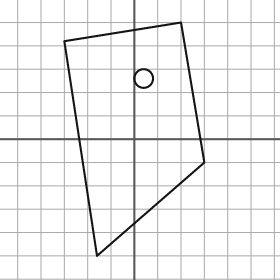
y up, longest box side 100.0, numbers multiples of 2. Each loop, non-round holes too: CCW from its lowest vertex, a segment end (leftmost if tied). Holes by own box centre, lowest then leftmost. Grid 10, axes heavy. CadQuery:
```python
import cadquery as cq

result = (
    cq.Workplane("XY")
    .moveTo(-16.0, -50.0)
    .lineTo(30.0, -10.0)
    .lineTo(20.0, 50.0)
    .lineTo(-30.0, 42.0)
    .close()
    .moveTo(4.0, 26.0)
    .circle(4.0)
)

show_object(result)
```